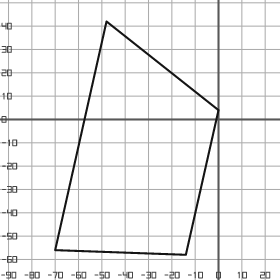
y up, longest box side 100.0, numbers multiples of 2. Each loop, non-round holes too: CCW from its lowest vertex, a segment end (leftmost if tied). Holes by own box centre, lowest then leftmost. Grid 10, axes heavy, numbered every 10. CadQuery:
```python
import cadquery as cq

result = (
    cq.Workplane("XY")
    .moveTo(-14.0, -58.0)
    .lineTo(0.0, 4.0)
    .lineTo(-48.0, 42.0)
    .lineTo(-70.0, -56.0)
    .close()
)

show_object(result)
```